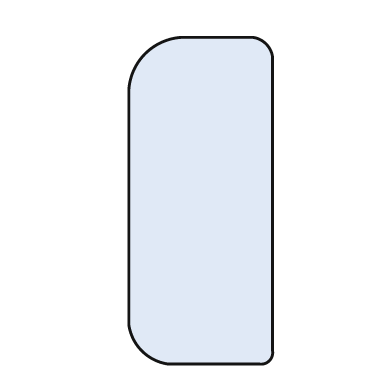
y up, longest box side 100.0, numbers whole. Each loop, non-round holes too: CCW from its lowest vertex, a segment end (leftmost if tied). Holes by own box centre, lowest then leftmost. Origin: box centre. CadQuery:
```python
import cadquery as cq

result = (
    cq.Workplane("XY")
    .moveTo(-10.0, -50.0)
    .lineTo(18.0, -50.0)
    .threePointArc((21.0, -49.0), (22.0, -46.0))
    .lineTo(22.0, 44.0)
    .threePointArc((20.0, 48.0), (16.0, 50.0))
    .lineTo(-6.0, 50.0)
    .threePointArc((-17.0, 45.0), (-22.0, 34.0))
    .lineTo(-22.0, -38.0)
    .threePointArc((-18.0, -46.0), (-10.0, -50.0))
    .close()
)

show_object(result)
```